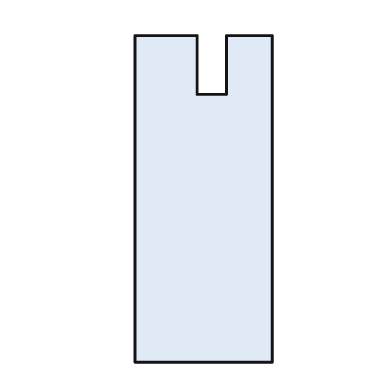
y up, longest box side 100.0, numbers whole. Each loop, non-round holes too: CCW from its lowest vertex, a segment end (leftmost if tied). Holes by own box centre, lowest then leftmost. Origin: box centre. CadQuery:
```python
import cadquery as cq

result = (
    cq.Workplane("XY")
    .moveTo(-21.0, -50.0)
    .lineTo(21.0, -50.0)
    .lineTo(21.0, 50.0)
    .lineTo(7.0, 50.0)
    .lineTo(7.0, 32.0)
    .lineTo(-2.0, 32.0)
    .lineTo(-2.0, 50.0)
    .lineTo(-21.0, 50.0)
    .close()
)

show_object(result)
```